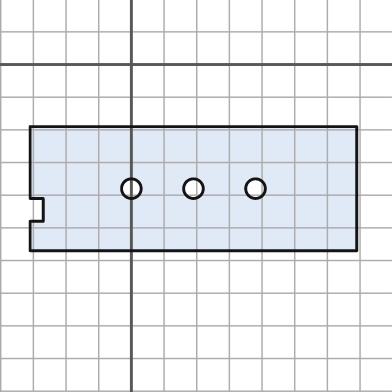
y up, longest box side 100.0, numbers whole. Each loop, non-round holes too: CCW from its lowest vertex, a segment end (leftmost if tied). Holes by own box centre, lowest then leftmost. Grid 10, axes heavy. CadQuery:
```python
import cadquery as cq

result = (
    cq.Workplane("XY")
    .moveTo(-31.0, -57.0)
    .lineTo(69.0, -57.0)
    .lineTo(69.0, -19.0)
    .lineTo(-31.0, -19.0)
    .lineTo(-31.0, -41.0)
    .lineTo(-27.0, -41.0)
    .lineTo(-27.0, -48.0)
    .lineTo(-31.0, -48.0)
    .close()
    .moveTo(0.0, -38.0)
    .circle(3.0)
    .moveTo(19.0, -38.0)
    .circle(3.0)
    .moveTo(38.0, -38.0)
    .circle(3.0)
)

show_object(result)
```